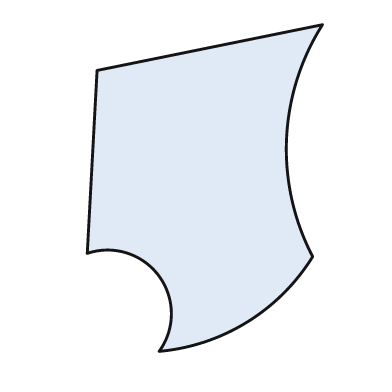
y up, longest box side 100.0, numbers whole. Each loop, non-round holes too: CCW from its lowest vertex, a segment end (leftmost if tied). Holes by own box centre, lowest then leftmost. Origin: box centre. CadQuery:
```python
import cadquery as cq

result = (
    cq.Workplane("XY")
    .moveTo(-14.0, -50.0)
    .threePointArc((13.0, -41.0), (33.0, -21.0))
    .threePointArc((25.0, 15.0), (36.0, 50.0))
    .lineTo(-33.0, 36.0)
    .lineTo(-36.0, -20.0)
    .threePointArc((-14.0, -27.0), (-14.0, -50.0))
    .close()
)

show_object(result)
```